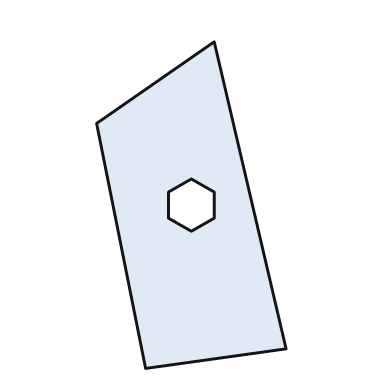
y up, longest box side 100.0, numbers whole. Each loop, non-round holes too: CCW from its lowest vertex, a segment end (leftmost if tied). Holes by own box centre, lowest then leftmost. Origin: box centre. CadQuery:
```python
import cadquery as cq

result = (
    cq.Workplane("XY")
    .moveTo(-14.0, -50.0)
    .lineTo(29.0, -44.0)
    .lineTo(7.0, 50.0)
    .lineTo(-29.0, 25.0)
    .close()
    .moveTo(0.0, -8.0)
    .lineTo(7.0, -4.0)
    .lineTo(7.0, 4.0)
    .lineTo(0.0, 8.0)
    .lineTo(-7.0, 4.0)
    .lineTo(-7.0, -4.0)
    .close()
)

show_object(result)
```